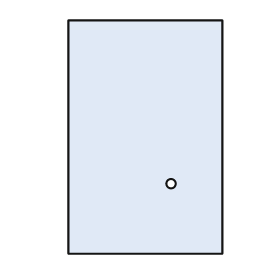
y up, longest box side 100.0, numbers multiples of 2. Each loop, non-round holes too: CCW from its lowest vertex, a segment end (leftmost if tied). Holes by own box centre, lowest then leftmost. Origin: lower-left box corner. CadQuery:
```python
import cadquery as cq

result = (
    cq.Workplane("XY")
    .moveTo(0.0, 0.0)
    .lineTo(66.0, 0.0)
    .lineTo(66.0, 100.0)
    .lineTo(0.0, 100.0)
    .close()
    .moveTo(44.0, 30.0)
    .circle(2.0)
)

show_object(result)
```